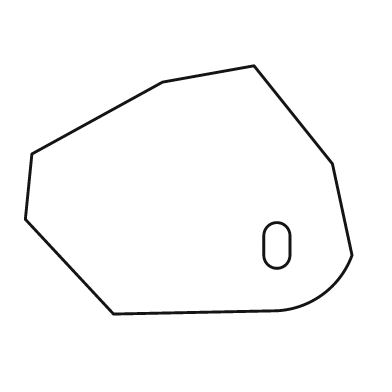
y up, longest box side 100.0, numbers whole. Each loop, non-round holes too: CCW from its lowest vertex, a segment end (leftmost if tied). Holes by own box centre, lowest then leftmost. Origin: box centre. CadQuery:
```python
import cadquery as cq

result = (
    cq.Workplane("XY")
    .moveTo(-23.0, -38.0)
    .lineTo(27.0, -37.0)
    .threePointArc((41.0, -32.0), (50.0, -20.0))
    .lineTo(44.0, 8.0)
    .lineTo(20.0, 38.0)
    .lineTo(-8.0, 33.0)
    .lineTo(-48.0, 11.0)
    .lineTo(-50.0, -9.0)
    .close()
    .moveTo(23.0, -20.0)
    .threePointArc((27.0, -24.0), (31.0, -20.0))
    .lineTo(31.0, -14.0)
    .threePointArc((27.0, -10.0), (23.0, -14.0))
    .close()
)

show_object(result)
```